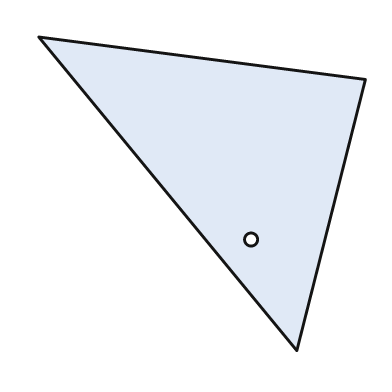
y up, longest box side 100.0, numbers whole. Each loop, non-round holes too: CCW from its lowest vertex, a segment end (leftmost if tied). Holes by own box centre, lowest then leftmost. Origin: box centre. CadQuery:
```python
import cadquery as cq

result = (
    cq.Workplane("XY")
    .moveTo(29.0, -48.0)
    .lineTo(50.0, 35.0)
    .lineTo(-50.0, 48.0)
    .close()
    .moveTo(15.0, -14.0)
    .circle(2.0)
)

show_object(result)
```